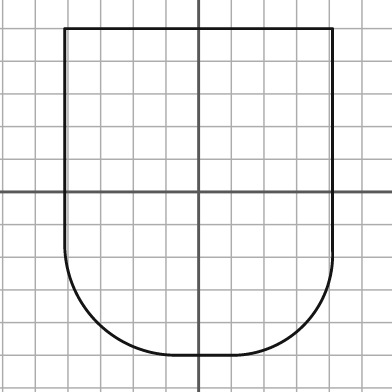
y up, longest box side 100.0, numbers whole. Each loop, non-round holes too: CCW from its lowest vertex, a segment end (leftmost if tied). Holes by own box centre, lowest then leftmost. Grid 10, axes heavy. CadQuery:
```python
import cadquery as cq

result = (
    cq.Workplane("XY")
    .moveTo(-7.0, -50.0)
    .lineTo(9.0, -50.0)
    .threePointArc((32.0, -41.0), (41.0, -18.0))
    .lineTo(41.0, 50.0)
    .lineTo(-41.0, 50.0)
    .lineTo(-41.0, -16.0)
    .threePointArc((-31.0, -40.0), (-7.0, -50.0))
    .close()
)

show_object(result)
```